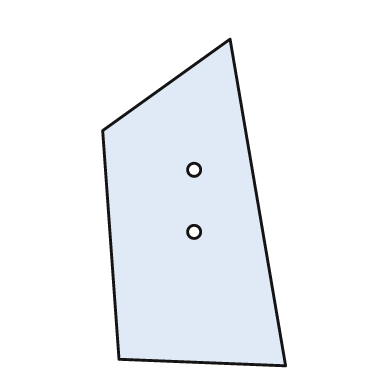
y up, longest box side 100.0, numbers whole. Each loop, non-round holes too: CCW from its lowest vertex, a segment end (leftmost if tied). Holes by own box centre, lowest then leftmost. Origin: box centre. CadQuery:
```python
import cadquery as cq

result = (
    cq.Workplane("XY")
    .moveTo(28.0, -50.0)
    .lineTo(11.0, 50.0)
    .lineTo(-28.0, 22.0)
    .lineTo(-23.0, -48.0)
    .close()
    .moveTo(0.0, -9.0)
    .circle(2.0)
    .moveTo(0.0, 10.0)
    .circle(2.0)
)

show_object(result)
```